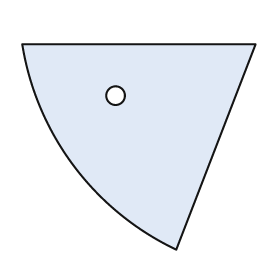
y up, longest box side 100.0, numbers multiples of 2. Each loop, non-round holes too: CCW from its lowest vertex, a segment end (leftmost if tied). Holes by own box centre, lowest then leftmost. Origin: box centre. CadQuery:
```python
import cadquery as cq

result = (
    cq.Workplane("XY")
    .moveTo(16.0, -44.0)
    .lineTo(50.0, 44.0)
    .lineTo(-50.0, 44.0)
    .threePointArc((-28.0, -8.0), (16.0, -44.0))
    .close()
    .moveTo(-10.0, 22.0)
    .circle(4.0)
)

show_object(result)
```